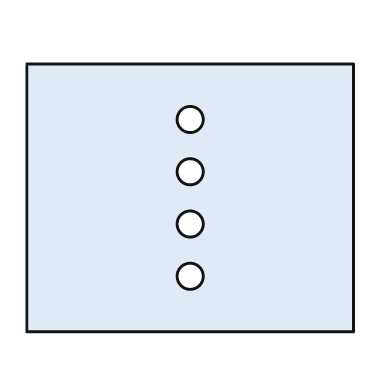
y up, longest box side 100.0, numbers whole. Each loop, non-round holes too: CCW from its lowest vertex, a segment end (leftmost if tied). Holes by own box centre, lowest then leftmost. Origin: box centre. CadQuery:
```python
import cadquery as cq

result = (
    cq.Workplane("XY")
    .moveTo(-50.0, -41.0)
    .lineTo(50.0, -41.0)
    .lineTo(50.0, 41.0)
    .lineTo(-50.0, 41.0)
    .close()
    .moveTo(0.0, -24.0)
    .circle(4.0)
    .moveTo(0.0, -8.0)
    .circle(4.0)
    .moveTo(0.0, 8.0)
    .circle(4.0)
    .moveTo(0.0, 24.0)
    .circle(4.0)
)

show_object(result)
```